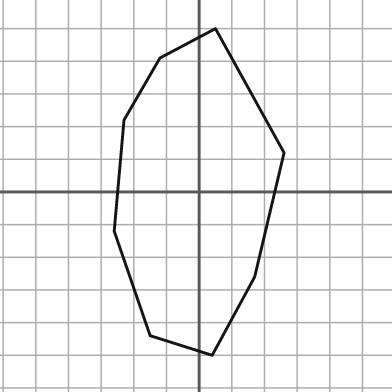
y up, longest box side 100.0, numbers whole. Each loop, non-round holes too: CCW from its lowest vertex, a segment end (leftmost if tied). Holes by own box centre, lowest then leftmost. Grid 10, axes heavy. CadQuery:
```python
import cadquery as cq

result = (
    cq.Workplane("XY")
    .moveTo(4.0, -50.0)
    .lineTo(17.0, -26.0)
    .lineTo(26.0, 12.0)
    .lineTo(5.0, 50.0)
    .lineTo(-12.0, 41.0)
    .lineTo(-23.0, 22.0)
    .lineTo(-26.0, -12.0)
    .lineTo(-15.0, -44.0)
    .close()
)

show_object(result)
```